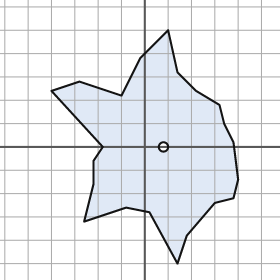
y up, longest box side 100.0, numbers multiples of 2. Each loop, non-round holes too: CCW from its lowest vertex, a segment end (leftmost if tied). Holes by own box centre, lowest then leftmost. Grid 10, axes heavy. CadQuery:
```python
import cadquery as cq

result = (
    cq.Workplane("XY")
    .moveTo(14.0, -50.0)
    .lineTo(18.0, -38.0)
    .lineTo(30.0, -24.0)
    .lineTo(38.0, -22.0)
    .lineTo(40.0, -14.0)
    .lineTo(38.0, 2.0)
    .lineTo(34.0, 10.0)
    .lineTo(32.0, 18.0)
    .lineTo(22.0, 24.0)
    .lineTo(14.0, 32.0)
    .lineTo(10.0, 50.0)
    .lineTo(-2.0, 38.0)
    .lineTo(-10.0, 22.0)
    .lineTo(-28.0, 28.0)
    .lineTo(-40.0, 24.0)
    .lineTo(-18.0, 0.0)
    .lineTo(-22.0, -6.0)
    .lineTo(-22.0, -16.0)
    .lineTo(-26.0, -32.0)
    .lineTo(-8.0, -26.0)
    .lineTo(2.0, -28.0)
    .close()
    .moveTo(8.0, 0.0)
    .circle(2.0)
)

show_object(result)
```